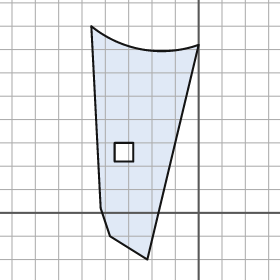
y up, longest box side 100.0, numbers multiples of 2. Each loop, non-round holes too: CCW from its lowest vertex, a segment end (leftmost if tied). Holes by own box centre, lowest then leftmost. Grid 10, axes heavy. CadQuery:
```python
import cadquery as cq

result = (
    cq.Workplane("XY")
    .moveTo(-22.0, -20.0)
    .lineTo(0.0, 72.0)
    .threePointArc((-24.0, 70.0), (-46.0, 80.0))
    .lineTo(-42.0, 2.0)
    .lineTo(-38.0, -10.0)
    .close()
    .moveTo(-36.0, 22.0)
    .lineTo(-28.0, 22.0)
    .lineTo(-28.0, 30.0)
    .lineTo(-36.0, 30.0)
    .close()
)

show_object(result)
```